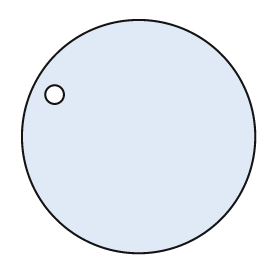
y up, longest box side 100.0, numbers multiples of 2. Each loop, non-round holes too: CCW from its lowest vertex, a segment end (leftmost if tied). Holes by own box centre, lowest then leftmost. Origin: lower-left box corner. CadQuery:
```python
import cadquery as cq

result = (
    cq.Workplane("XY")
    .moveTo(50.0, 50.0)
    .circle(50.0)
    .moveTo(14.0, 68.0)
    .circle(4.0)
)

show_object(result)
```